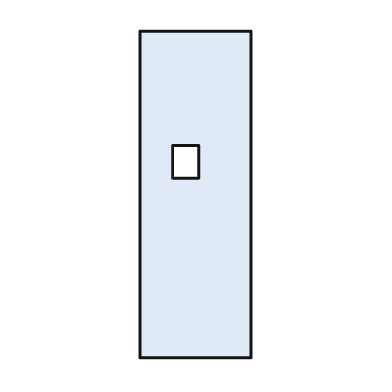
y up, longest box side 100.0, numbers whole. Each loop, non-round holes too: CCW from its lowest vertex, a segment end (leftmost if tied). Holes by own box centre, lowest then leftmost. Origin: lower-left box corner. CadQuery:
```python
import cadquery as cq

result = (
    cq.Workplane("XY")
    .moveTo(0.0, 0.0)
    .lineTo(34.0, 0.0)
    .lineTo(34.0, 100.0)
    .lineTo(0.0, 100.0)
    .close()
    .moveTo(10.0, 55.0)
    .lineTo(18.0, 55.0)
    .lineTo(18.0, 65.0)
    .lineTo(10.0, 65.0)
    .close()
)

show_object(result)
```